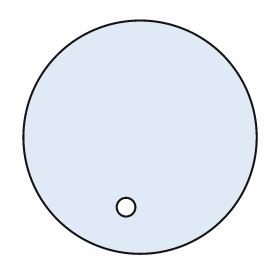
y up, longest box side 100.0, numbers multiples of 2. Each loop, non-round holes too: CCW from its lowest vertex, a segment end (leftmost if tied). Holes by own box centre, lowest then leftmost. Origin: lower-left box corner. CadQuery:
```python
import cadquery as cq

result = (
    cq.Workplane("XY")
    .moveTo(50.0, 50.0)
    .circle(50.0)
    .moveTo(44.0, 20.0)
    .circle(4.0)
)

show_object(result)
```